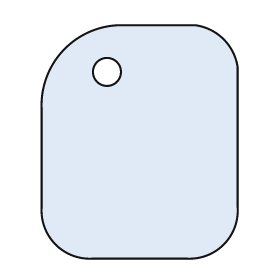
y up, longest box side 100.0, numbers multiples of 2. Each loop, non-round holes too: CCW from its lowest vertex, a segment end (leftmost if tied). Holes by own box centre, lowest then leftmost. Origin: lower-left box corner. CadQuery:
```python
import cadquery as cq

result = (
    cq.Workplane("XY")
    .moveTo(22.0, 0.0)
    .lineTo(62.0, 0.0)
    .threePointArc((78.0, 6.0), (84.0, 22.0))
    .lineTo(84.0, 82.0)
    .threePointArc((78.0, 94.0), (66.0, 100.0))
    .lineTo(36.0, 100.0)
    .threePointArc((10.0, 90.0), (0.0, 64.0))
    .lineTo(0.0, 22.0)
    .threePointArc((6.0, 6.0), (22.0, 0.0))
    .close()
    .moveTo(28.0, 80.0)
    .circle(6.0)
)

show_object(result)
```